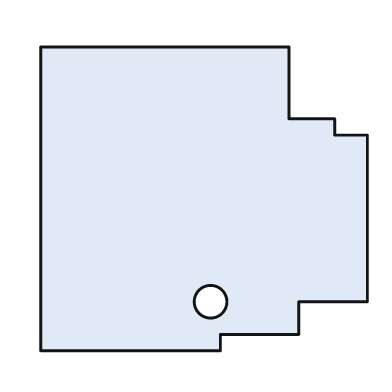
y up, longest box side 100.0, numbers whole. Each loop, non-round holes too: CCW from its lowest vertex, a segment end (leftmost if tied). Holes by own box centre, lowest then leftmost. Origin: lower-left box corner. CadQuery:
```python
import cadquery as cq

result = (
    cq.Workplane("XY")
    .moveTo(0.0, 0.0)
    .lineTo(55.0, 0.0)
    .lineTo(55.0, 5.0)
    .lineTo(79.0, 5.0)
    .lineTo(79.0, 15.0)
    .lineTo(100.0, 15.0)
    .lineTo(100.0, 66.0)
    .lineTo(90.0, 66.0)
    .lineTo(90.0, 71.0)
    .lineTo(76.0, 71.0)
    .lineTo(76.0, 93.0)
    .lineTo(0.0, 93.0)
    .close()
    .moveTo(52.0, 15.0)
    .circle(5.0)
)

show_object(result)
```